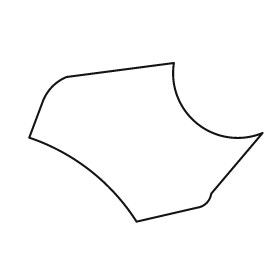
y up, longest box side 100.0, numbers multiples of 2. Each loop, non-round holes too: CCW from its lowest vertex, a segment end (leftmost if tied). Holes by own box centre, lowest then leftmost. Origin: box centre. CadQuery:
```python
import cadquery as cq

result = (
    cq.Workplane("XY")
    .moveTo(-4.0, -34.0)
    .lineTo(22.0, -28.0)
    .threePointArc((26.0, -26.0), (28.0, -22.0))
    .lineTo(50.0, 4.0)
    .threePointArc((22.0, 8.0), (12.0, 34.0))
    .lineTo(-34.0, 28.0)
    .threePointArc((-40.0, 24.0), (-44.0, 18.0))
    .lineTo(-50.0, 2.0)
    .threePointArc((-24.0, -12.0), (-4.0, -34.0))
    .close()
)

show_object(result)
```